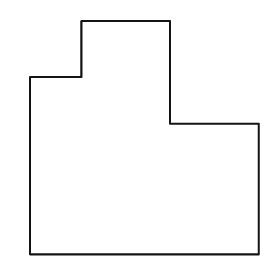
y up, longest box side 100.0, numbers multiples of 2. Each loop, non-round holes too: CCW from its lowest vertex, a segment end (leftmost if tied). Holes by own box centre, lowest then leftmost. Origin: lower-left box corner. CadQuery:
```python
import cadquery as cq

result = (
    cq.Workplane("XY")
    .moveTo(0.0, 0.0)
    .lineTo(98.0, 0.0)
    .lineTo(98.0, 56.0)
    .lineTo(60.0, 56.0)
    .lineTo(60.0, 100.0)
    .lineTo(22.0, 100.0)
    .lineTo(22.0, 76.0)
    .lineTo(0.0, 76.0)
    .close()
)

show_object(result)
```